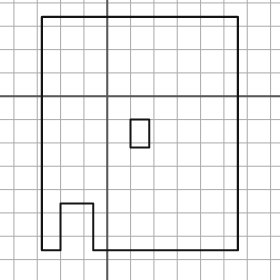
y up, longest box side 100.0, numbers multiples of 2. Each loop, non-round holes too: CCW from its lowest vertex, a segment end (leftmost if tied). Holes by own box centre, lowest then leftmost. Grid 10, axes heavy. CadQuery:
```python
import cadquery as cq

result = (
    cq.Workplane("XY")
    .moveTo(-28.0, -66.0)
    .lineTo(-20.0, -66.0)
    .lineTo(-20.0, -46.0)
    .lineTo(-6.0, -46.0)
    .lineTo(-6.0, -66.0)
    .lineTo(56.0, -66.0)
    .lineTo(56.0, 34.0)
    .lineTo(-28.0, 34.0)
    .close()
    .moveTo(10.0, -22.0)
    .lineTo(18.0, -22.0)
    .lineTo(18.0, -10.0)
    .lineTo(10.0, -10.0)
    .close()
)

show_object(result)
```